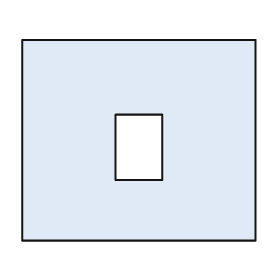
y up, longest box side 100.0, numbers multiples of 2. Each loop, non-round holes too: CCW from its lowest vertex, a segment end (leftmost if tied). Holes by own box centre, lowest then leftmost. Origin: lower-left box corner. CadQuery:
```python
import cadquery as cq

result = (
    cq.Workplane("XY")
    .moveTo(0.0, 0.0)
    .lineTo(100.0, 0.0)
    .lineTo(100.0, 86.0)
    .lineTo(0.0, 86.0)
    .close()
    .moveTo(40.0, 26.0)
    .lineTo(60.0, 26.0)
    .lineTo(60.0, 54.0)
    .lineTo(40.0, 54.0)
    .close()
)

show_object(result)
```